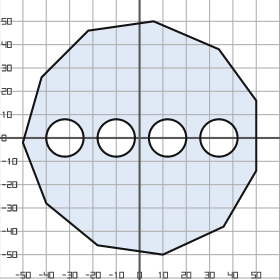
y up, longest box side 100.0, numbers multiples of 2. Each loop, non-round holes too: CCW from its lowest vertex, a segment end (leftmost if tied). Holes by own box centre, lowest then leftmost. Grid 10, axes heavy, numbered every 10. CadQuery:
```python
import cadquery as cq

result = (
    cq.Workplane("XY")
    .moveTo(10.0, -50.0)
    .lineTo(36.0, -38.0)
    .lineTo(50.0, -14.0)
    .lineTo(50.0, 16.0)
    .lineTo(34.0, 38.0)
    .lineTo(6.0, 50.0)
    .lineTo(-22.0, 46.0)
    .lineTo(-42.0, 26.0)
    .lineTo(-50.0, -2.0)
    .lineTo(-40.0, -28.0)
    .lineTo(-18.0, -46.0)
    .close()
    .moveTo(-32.0, 0.0)
    .circle(8.0)
    .moveTo(-10.0, 0.0)
    .circle(8.0)
    .moveTo(12.0, 0.0)
    .circle(8.0)
    .moveTo(34.0, 0.0)
    .circle(8.0)
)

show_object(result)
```